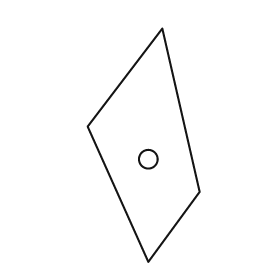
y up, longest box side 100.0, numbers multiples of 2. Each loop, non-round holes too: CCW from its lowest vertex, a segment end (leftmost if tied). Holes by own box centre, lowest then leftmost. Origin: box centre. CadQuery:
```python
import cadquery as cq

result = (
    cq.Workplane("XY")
    .moveTo(2.0, -50.0)
    .lineTo(24.0, -20.0)
    .lineTo(8.0, 50.0)
    .lineTo(-24.0, 8.0)
    .close()
    .moveTo(2.0, -6.0)
    .circle(4.0)
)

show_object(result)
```